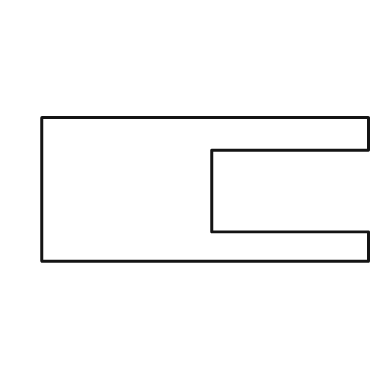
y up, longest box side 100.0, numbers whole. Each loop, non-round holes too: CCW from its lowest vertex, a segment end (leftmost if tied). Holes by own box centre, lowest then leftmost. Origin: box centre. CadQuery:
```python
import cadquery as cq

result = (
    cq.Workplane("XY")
    .moveTo(-50.0, -22.0)
    .lineTo(50.0, -22.0)
    .lineTo(50.0, -13.0)
    .lineTo(2.0, -13.0)
    .lineTo(2.0, 12.0)
    .lineTo(50.0, 12.0)
    .lineTo(50.0, 22.0)
    .lineTo(-50.0, 22.0)
    .close()
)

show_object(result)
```